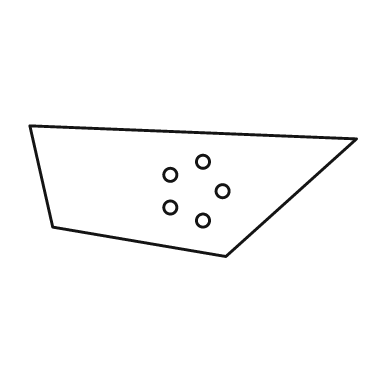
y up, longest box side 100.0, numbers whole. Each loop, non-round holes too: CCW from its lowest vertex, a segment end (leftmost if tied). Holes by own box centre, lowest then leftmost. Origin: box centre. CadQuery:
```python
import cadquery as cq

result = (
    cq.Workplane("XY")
    .moveTo(10.0, -20.0)
    .lineTo(50.0, 16.0)
    .lineTo(-50.0, 20.0)
    .lineTo(-43.0, -11.0)
    .close()
    .moveTo(3.0, -9.0)
    .circle(2.0)
    .moveTo(-7.0, -5.0)
    .circle(2.0)
    .moveTo(9.0, 0.0)
    .circle(2.0)
    .moveTo(-7.0, 5.0)
    .circle(2.0)
    .moveTo(3.0, 9.0)
    .circle(2.0)
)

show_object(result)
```